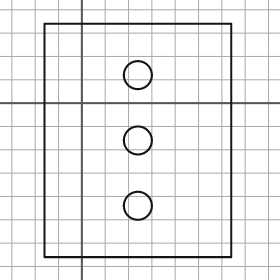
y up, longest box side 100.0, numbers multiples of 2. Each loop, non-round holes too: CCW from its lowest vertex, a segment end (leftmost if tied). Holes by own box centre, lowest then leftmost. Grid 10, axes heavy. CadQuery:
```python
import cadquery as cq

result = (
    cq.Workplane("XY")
    .moveTo(-16.0, -66.0)
    .lineTo(64.0, -66.0)
    .lineTo(64.0, 34.0)
    .lineTo(-16.0, 34.0)
    .close()
    .moveTo(24.0, -44.0)
    .circle(6.0)
    .moveTo(24.0, -16.0)
    .circle(6.0)
    .moveTo(24.0, 12.0)
    .circle(6.0)
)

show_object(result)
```